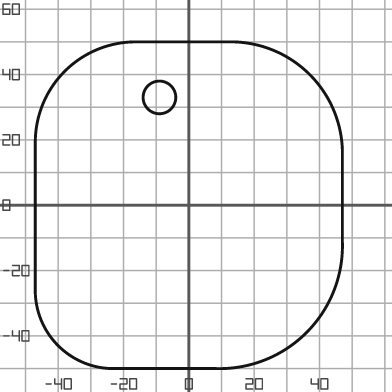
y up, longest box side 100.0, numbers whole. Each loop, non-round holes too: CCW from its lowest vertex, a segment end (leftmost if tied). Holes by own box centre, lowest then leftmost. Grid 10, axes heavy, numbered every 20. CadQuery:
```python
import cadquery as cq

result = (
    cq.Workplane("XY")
    .moveTo(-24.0, -50.0)
    .lineTo(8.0, -50.0)
    .threePointArc((36.0, -39.0), (47.0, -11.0))
    .lineTo(47.0, 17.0)
    .threePointArc((37.0, 40.0), (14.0, 50.0))
    .lineTo(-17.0, 50.0)
    .threePointArc((-38.0, 41.0), (-47.0, 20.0))
    .lineTo(-47.0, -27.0)
    .threePointArc((-40.0, -43.0), (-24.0, -50.0))
    .close()
    .moveTo(-9.0, 33.0)
    .circle(5.0)
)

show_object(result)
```